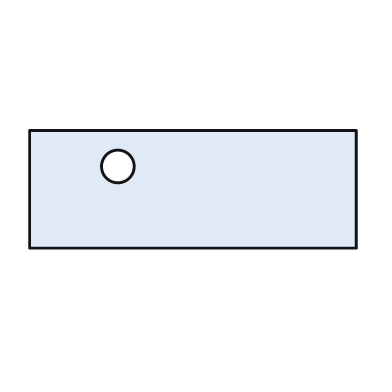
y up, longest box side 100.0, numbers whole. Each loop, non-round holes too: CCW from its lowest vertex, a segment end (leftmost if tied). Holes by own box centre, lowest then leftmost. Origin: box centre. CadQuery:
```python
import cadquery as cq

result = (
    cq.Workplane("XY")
    .moveTo(-50.0, -18.0)
    .lineTo(50.0, -18.0)
    .lineTo(50.0, 18.0)
    .lineTo(-50.0, 18.0)
    .close()
    .moveTo(-23.0, 7.0)
    .circle(5.0)
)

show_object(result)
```